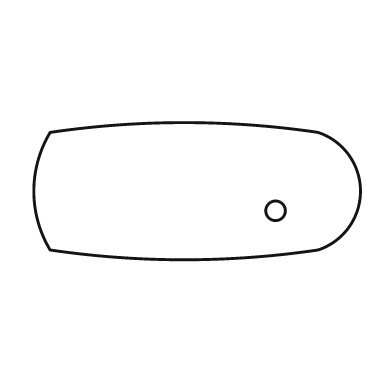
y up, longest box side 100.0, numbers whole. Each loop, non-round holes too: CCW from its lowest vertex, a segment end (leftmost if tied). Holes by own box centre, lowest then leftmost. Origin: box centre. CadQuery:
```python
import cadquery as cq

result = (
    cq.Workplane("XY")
    .moveTo(-45.0, -18.0)
    .threePointArc((-4.0, -21.0), (37.0, -18.0))
    .threePointArc((50.0, 0.0), (37.0, 18.0))
    .threePointArc((-4.0, 21.0), (-45.0, 18.0))
    .threePointArc((-50.0, 0.0), (-45.0, -18.0))
    .close()
    .moveTo(24.0, -6.0)
    .circle(3.0)
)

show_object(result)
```